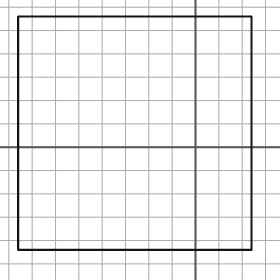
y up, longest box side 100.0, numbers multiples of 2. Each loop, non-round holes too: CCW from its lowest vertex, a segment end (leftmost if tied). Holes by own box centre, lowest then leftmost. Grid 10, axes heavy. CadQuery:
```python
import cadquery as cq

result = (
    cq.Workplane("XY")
    .moveTo(-76.0, -44.0)
    .lineTo(24.0, -44.0)
    .lineTo(24.0, 56.0)
    .lineTo(-76.0, 56.0)
    .close()
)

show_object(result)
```